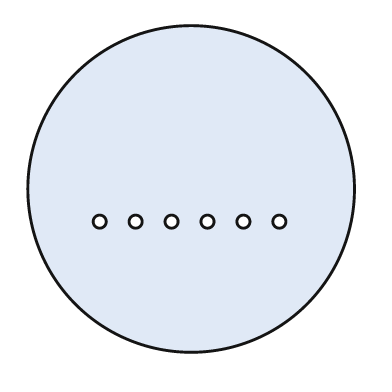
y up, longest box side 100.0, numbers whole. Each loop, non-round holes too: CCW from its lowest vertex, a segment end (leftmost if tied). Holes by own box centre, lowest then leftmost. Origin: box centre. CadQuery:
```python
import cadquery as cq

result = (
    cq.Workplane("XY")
    .moveTo(0.0, 0.0)
    .circle(50.0)
    .moveTo(-28.0, -10.0)
    .circle(2.0)
    .moveTo(-17.0, -10.0)
    .circle(2.0)
    .moveTo(-6.0, -10.0)
    .circle(2.0)
    .moveTo(5.0, -10.0)
    .circle(2.0)
    .moveTo(16.0, -10.0)
    .circle(2.0)
    .moveTo(27.0, -10.0)
    .circle(2.0)
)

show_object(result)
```